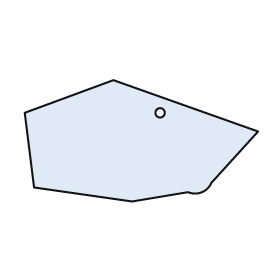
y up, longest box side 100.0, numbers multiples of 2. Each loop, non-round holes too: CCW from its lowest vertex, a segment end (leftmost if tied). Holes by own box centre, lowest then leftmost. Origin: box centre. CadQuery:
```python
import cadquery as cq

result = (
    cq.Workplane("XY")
    .moveTo(-4.0, -26.0)
    .lineTo(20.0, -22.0)
    .threePointArc((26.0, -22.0), (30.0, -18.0))
    .lineTo(50.0, 4.0)
    .lineTo(-12.0, 26.0)
    .lineTo(-50.0, 12.0)
    .lineTo(-46.0, -20.0)
    .close()
    .moveTo(8.0, 12.0)
    .circle(2.0)
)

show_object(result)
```